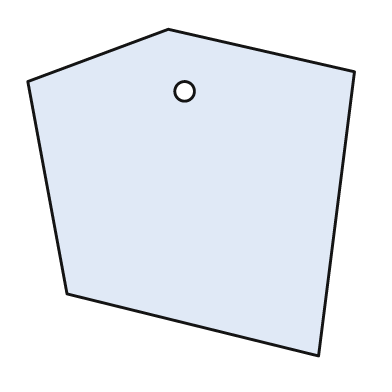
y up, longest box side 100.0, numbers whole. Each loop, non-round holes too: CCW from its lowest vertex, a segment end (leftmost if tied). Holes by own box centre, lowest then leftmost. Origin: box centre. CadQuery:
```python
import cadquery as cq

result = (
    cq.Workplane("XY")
    .moveTo(39.0, -50.0)
    .lineTo(50.0, 37.0)
    .lineTo(-7.0, 50.0)
    .lineTo(-50.0, 34.0)
    .lineTo(-38.0, -31.0)
    .close()
    .moveTo(-2.0, 31.0)
    .circle(3.0)
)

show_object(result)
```